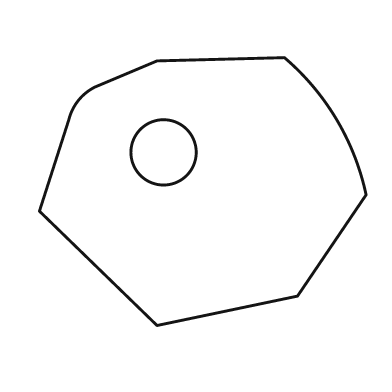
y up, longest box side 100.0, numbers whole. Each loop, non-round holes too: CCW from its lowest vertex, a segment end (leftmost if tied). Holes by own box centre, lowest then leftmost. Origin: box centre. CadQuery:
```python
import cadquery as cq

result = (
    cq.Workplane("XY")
    .moveTo(-14.0, -41.0)
    .lineTo(29.0, -32.0)
    .lineTo(50.0, -1.0)
    .threePointArc((41.0, 22.0), (25.0, 41.0))
    .lineTo(-14.0, 40.0)
    .lineTo(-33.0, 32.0)
    .threePointArc((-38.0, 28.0), (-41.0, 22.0))
    .lineTo(-50.0, -6.0)
    .close()
    .moveTo(-12.0, 12.0)
    .circle(10.0)
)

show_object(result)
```